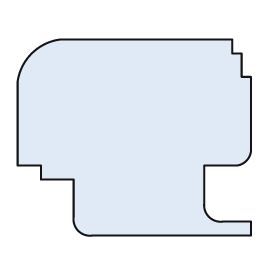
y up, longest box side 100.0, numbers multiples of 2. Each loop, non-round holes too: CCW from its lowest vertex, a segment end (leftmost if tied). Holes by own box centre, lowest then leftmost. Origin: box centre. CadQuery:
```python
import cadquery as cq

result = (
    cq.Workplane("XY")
    .moveTo(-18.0, -42.0)
    .lineTo(50.0, -42.0)
    .lineTo(50.0, -36.0)
    .lineTo(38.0, -36.0)
    .threePointArc((32.0, -34.0), (30.0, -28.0))
    .lineTo(30.0, -12.0)
    .lineTo(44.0, -12.0)
    .threePointArc((48.0, -10.0), (50.0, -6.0))
    .lineTo(50.0, 26.0)
    .lineTo(46.0, 26.0)
    .lineTo(46.0, 36.0)
    .lineTo(42.0, 36.0)
    .lineTo(42.0, 42.0)
    .lineTo(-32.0, 42.0)
    .threePointArc((-44.0, 36.0), (-50.0, 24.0))
    .lineTo(-50.0, -12.0)
    .lineTo(-40.0, -12.0)
    .lineTo(-40.0, -18.0)
    .lineTo(-26.0, -18.0)
    .lineTo(-26.0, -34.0)
    .threePointArc((-24.0, -40.0), (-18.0, -42.0))
    .close()
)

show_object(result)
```